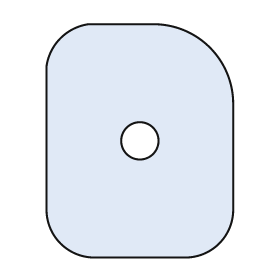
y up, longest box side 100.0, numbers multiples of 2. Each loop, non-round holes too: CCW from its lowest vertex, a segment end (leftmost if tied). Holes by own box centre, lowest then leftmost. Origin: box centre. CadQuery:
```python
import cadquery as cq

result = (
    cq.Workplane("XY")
    .moveTo(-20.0, -50.0)
    .lineTo(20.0, -50.0)
    .threePointArc((34.0, -44.0), (40.0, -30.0))
    .lineTo(40.0, 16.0)
    .threePointArc((30.0, 40.0), (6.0, 50.0))
    .lineTo(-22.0, 50.0)
    .threePointArc((-34.0, 44.0), (-40.0, 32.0))
    .lineTo(-40.0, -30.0)
    .threePointArc((-34.0, -44.0), (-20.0, -50.0))
    .close()
    .moveTo(0.0, 0.0)
    .circle(8.0)
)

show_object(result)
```